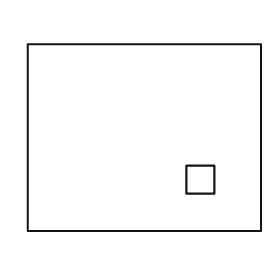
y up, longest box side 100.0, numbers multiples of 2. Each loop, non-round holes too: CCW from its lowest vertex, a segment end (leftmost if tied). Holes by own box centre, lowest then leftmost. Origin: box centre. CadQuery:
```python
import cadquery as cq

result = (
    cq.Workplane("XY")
    .moveTo(-50.0, -40.0)
    .lineTo(50.0, -40.0)
    .lineTo(50.0, 40.0)
    .lineTo(-50.0, 40.0)
    .close()
    .moveTo(18.0, -24.0)
    .lineTo(30.0, -24.0)
    .lineTo(30.0, -12.0)
    .lineTo(18.0, -12.0)
    .close()
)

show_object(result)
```